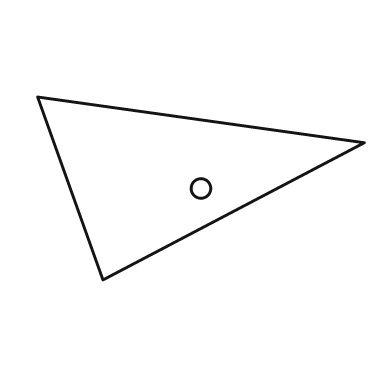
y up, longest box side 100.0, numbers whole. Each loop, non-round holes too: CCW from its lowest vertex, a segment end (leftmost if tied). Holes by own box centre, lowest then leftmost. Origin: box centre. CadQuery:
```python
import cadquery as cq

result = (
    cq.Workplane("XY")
    .moveTo(-30.0, -28.0)
    .lineTo(50.0, 14.0)
    .lineTo(-50.0, 28.0)
    .close()
    .moveTo(0.0, 0.0)
    .circle(3.0)
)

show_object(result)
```